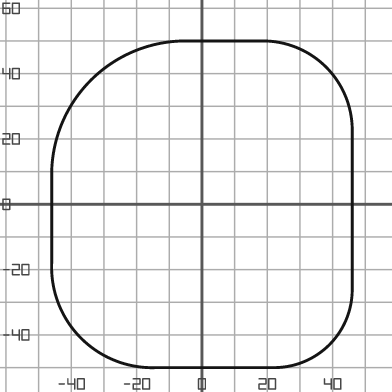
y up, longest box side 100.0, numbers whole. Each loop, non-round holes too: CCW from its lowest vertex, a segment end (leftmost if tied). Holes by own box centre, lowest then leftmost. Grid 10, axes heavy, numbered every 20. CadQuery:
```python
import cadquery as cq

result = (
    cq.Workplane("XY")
    .moveTo(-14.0, -50.0)
    .lineTo(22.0, -50.0)
    .threePointArc((39.0, -43.0), (46.0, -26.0))
    .lineTo(46.0, 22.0)
    .threePointArc((38.0, 42.0), (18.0, 50.0))
    .lineTo(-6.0, 50.0)
    .threePointArc((-34.0, 38.0), (-46.0, 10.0))
    .lineTo(-46.0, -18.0)
    .threePointArc((-37.0, -41.0), (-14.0, -50.0))
    .close()
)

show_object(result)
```